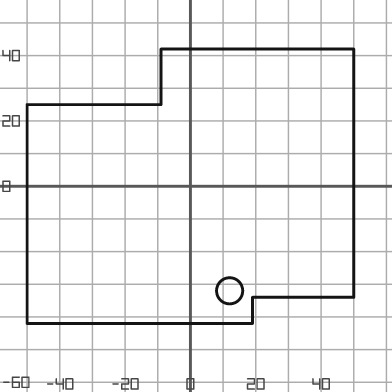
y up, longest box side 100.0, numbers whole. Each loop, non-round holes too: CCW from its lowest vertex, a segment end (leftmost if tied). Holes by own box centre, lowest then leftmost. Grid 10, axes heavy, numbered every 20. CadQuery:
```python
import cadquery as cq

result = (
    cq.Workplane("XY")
    .moveTo(-50.0, -42.0)
    .lineTo(19.0, -42.0)
    .lineTo(19.0, -34.0)
    .lineTo(50.0, -34.0)
    .lineTo(50.0, 42.0)
    .lineTo(-9.0, 42.0)
    .lineTo(-9.0, 25.0)
    .lineTo(-50.0, 25.0)
    .close()
    .moveTo(12.0, -32.0)
    .circle(4.0)
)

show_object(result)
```